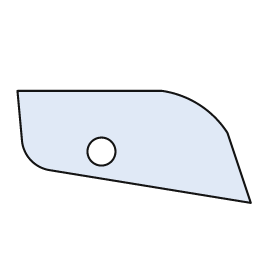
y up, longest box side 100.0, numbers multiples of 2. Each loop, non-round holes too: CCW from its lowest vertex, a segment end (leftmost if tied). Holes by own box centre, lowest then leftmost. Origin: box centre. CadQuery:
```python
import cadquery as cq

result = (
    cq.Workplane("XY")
    .moveTo(50.0, -24.0)
    .lineTo(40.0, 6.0)
    .threePointArc((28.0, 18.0), (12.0, 24.0))
    .lineTo(-50.0, 24.0)
    .lineTo(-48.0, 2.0)
    .threePointArc((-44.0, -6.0), (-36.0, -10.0))
    .close()
    .moveTo(-14.0, -2.0)
    .circle(6.0)
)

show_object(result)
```